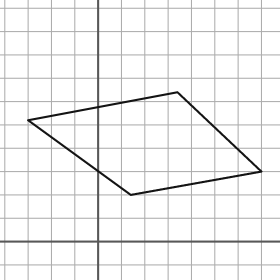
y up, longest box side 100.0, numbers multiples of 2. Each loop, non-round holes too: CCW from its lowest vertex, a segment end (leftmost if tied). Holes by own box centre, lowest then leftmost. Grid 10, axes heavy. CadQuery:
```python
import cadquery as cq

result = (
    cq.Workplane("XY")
    .moveTo(14.0, 20.0)
    .lineTo(70.0, 30.0)
    .lineTo(34.0, 64.0)
    .lineTo(-30.0, 52.0)
    .close()
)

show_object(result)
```